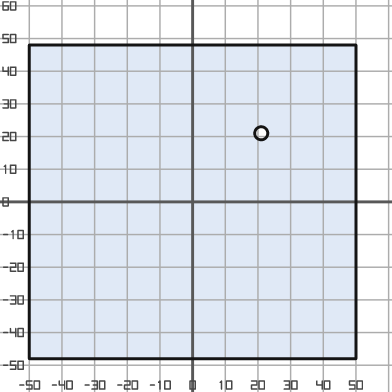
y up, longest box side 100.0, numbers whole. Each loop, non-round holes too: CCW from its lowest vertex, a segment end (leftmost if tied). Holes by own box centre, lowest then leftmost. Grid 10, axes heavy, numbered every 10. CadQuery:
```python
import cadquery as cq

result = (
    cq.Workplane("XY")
    .moveTo(-50.0, -48.0)
    .lineTo(50.0, -48.0)
    .lineTo(50.0, 48.0)
    .lineTo(-50.0, 48.0)
    .close()
    .moveTo(21.0, 21.0)
    .circle(2.0)
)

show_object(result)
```